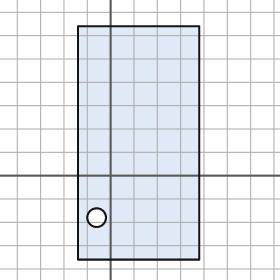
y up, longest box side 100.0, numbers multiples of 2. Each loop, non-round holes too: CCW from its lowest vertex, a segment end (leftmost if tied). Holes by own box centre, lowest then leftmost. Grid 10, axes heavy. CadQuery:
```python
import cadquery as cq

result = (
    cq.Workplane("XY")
    .moveTo(-14.0, -36.0)
    .lineTo(38.0, -36.0)
    .lineTo(38.0, 64.0)
    .lineTo(-14.0, 64.0)
    .close()
    .moveTo(-6.0, -18.0)
    .circle(4.0)
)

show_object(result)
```